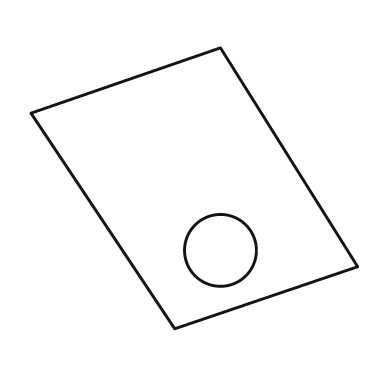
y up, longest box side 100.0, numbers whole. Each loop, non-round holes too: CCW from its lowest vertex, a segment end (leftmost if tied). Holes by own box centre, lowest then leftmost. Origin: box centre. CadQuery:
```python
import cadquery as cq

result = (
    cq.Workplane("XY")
    .moveTo(-6.0, -43.0)
    .lineTo(50.0, -24.0)
    .lineTo(8.0, 43.0)
    .lineTo(-50.0, 23.0)
    .close()
    .moveTo(8.0, -19.0)
    .circle(11.0)
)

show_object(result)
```